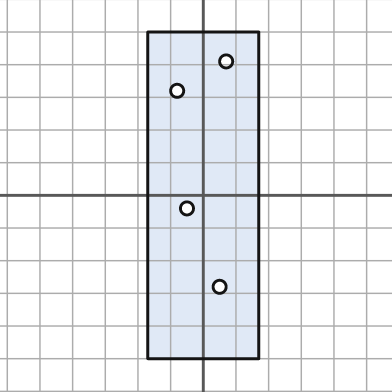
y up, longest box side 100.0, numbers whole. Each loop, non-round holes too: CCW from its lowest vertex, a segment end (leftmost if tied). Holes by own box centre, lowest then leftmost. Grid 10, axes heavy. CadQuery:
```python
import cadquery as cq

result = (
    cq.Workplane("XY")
    .moveTo(-17.0, -50.0)
    .lineTo(17.0, -50.0)
    .lineTo(17.0, 50.0)
    .lineTo(-17.0, 50.0)
    .close()
    .moveTo(5.0, -28.0)
    .circle(2.0)
    .moveTo(-5.0, -4.0)
    .circle(2.0)
    .moveTo(-8.0, 32.0)
    .circle(2.0)
    .moveTo(7.0, 41.0)
    .circle(2.0)
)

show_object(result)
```